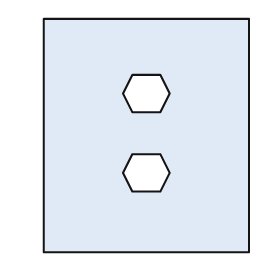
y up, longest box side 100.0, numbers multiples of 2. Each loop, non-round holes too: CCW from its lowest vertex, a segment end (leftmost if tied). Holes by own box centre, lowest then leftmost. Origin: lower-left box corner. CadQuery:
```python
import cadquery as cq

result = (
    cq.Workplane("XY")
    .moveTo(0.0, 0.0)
    .lineTo(88.0, 0.0)
    .lineTo(88.0, 100.0)
    .lineTo(0.0, 100.0)
    .close()
    .moveTo(38.0, 26.0)
    .lineTo(50.0, 26.0)
    .lineTo(54.0, 34.0)
    .lineTo(50.0, 42.0)
    .lineTo(38.0, 42.0)
    .lineTo(34.0, 34.0)
    .close()
    .moveTo(38.0, 60.0)
    .lineTo(50.0, 60.0)
    .lineTo(54.0, 68.0)
    .lineTo(50.0, 76.0)
    .lineTo(38.0, 76.0)
    .lineTo(34.0, 68.0)
    .close()
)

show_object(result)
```